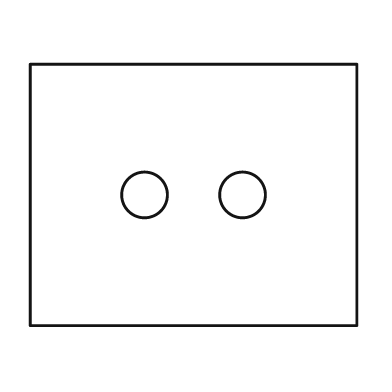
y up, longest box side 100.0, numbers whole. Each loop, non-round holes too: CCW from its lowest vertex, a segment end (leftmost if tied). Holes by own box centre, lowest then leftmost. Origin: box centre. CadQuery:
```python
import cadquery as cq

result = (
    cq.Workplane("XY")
    .moveTo(-50.0, -40.0)
    .lineTo(50.0, -40.0)
    .lineTo(50.0, 40.0)
    .lineTo(-50.0, 40.0)
    .close()
    .moveTo(-15.0, 0.0)
    .circle(7.0)
    .moveTo(15.0, 0.0)
    .circle(7.0)
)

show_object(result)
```